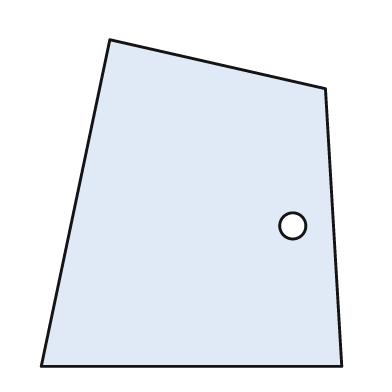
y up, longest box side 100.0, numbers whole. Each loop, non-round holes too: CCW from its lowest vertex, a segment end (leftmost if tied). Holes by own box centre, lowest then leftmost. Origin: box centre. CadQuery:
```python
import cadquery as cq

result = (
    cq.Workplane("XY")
    .moveTo(-46.0, -50.0)
    .lineTo(46.0, -50.0)
    .lineTo(41.0, 35.0)
    .lineTo(-25.0, 50.0)
    .close()
    .moveTo(31.0, -7.0)
    .circle(4.0)
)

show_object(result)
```